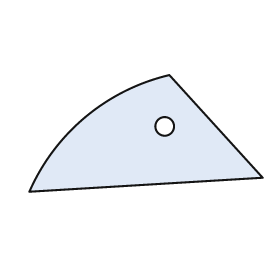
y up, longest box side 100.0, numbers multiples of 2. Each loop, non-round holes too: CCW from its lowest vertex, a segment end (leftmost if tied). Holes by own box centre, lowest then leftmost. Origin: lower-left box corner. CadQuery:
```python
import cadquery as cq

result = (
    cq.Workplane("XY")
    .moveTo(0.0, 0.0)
    .lineTo(100.0, 6.0)
    .lineTo(60.0, 50.0)
    .threePointArc((24.0, 32.0), (0.0, 0.0))
    .close()
    .moveTo(58.0, 28.0)
    .circle(4.0)
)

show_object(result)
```